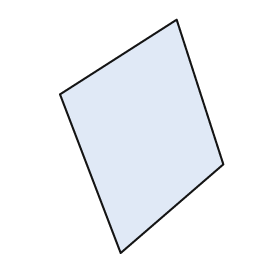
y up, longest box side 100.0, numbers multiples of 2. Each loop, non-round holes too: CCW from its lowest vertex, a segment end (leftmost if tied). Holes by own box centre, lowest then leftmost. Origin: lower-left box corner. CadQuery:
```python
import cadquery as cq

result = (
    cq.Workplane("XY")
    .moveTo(26.0, 0.0)
    .lineTo(70.0, 38.0)
    .lineTo(50.0, 100.0)
    .lineTo(0.0, 68.0)
    .close()
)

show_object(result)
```